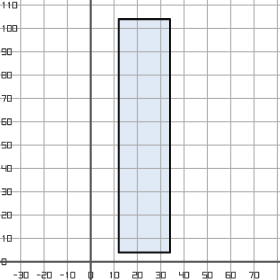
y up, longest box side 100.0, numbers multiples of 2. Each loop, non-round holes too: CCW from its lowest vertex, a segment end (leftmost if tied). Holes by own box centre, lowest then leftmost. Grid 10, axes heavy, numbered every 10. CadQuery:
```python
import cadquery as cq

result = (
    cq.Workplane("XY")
    .moveTo(12.0, 4.0)
    .lineTo(34.0, 4.0)
    .lineTo(34.0, 104.0)
    .lineTo(12.0, 104.0)
    .close()
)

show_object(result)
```